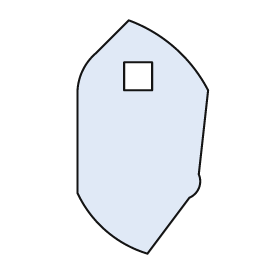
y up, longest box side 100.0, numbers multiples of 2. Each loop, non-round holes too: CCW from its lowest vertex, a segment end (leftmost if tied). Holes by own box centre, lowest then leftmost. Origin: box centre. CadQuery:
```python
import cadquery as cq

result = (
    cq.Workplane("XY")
    .moveTo(2.0, -50.0)
    .lineTo(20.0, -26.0)
    .threePointArc((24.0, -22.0), (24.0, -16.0))
    .lineTo(28.0, 20.0)
    .threePointArc((14.0, 38.0), (-6.0, 50.0))
    .lineTo(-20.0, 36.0)
    .threePointArc((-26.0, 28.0), (-28.0, 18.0))
    .lineTo(-28.0, -24.0)
    .threePointArc((-16.0, -40.0), (2.0, -50.0))
    .close()
    .moveTo(-8.0, 20.0)
    .lineTo(4.0, 20.0)
    .lineTo(4.0, 32.0)
    .lineTo(-8.0, 32.0)
    .close()
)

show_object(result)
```